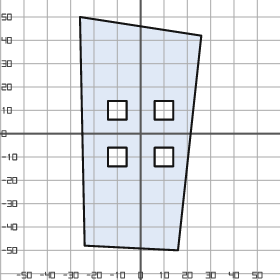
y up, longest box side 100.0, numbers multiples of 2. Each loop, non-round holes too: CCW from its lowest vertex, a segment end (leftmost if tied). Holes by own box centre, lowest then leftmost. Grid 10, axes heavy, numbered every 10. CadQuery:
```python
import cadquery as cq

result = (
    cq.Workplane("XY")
    .moveTo(16.0, -50.0)
    .lineTo(26.0, 42.0)
    .lineTo(-26.0, 50.0)
    .lineTo(-24.0, -48.0)
    .close()
    .moveTo(-14.0, -14.0)
    .lineTo(-6.0, -14.0)
    .lineTo(-6.0, -6.0)
    .lineTo(-14.0, -6.0)
    .close()
    .moveTo(6.0, -14.0)
    .lineTo(14.0, -14.0)
    .lineTo(14.0, -6.0)
    .lineTo(6.0, -6.0)
    .close()
    .moveTo(-14.0, 6.0)
    .lineTo(-6.0, 6.0)
    .lineTo(-6.0, 14.0)
    .lineTo(-14.0, 14.0)
    .close()
    .moveTo(6.0, 6.0)
    .lineTo(14.0, 6.0)
    .lineTo(14.0, 14.0)
    .lineTo(6.0, 14.0)
    .close()
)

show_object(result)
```